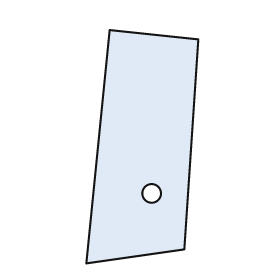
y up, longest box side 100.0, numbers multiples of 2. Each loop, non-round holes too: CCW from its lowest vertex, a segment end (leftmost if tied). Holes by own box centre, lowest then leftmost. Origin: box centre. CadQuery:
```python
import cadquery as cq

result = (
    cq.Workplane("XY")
    .moveTo(-24.0, -50.0)
    .lineTo(18.0, -44.0)
    .lineTo(24.0, 46.0)
    .lineTo(-14.0, 50.0)
    .close()
    .moveTo(4.0, -20.0)
    .circle(4.0)
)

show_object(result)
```